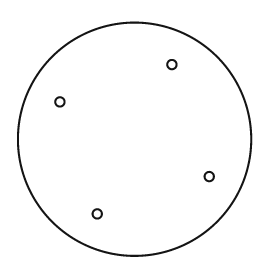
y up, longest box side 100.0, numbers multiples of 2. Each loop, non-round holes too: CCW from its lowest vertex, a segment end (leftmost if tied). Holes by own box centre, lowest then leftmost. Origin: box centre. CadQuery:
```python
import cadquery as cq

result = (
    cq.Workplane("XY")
    .moveTo(0.0, 0.0)
    .circle(50.0)
    .moveTo(-16.0, -32.0)
    .circle(2.0)
    .moveTo(32.0, -16.0)
    .circle(2.0)
    .moveTo(-32.0, 16.0)
    .circle(2.0)
    .moveTo(16.0, 32.0)
    .circle(2.0)
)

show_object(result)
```